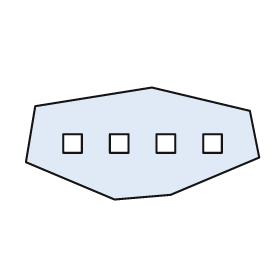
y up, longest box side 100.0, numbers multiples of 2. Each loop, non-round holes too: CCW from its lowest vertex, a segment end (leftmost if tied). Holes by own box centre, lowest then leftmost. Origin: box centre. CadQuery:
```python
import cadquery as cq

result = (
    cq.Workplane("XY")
    .moveTo(-12.0, -24.0)
    .lineTo(12.0, -22.0)
    .lineTo(50.0, -6.0)
    .lineTo(46.0, 14.0)
    .lineTo(4.0, 24.0)
    .lineTo(-46.0, 16.0)
    .lineTo(-50.0, -8.0)
    .close()
    .moveTo(-34.0, -4.0)
    .lineTo(-26.0, -4.0)
    .lineTo(-26.0, 4.0)
    .lineTo(-34.0, 4.0)
    .close()
    .moveTo(-14.0, -4.0)
    .lineTo(-6.0, -4.0)
    .lineTo(-6.0, 4.0)
    .lineTo(-14.0, 4.0)
    .close()
    .moveTo(6.0, -4.0)
    .lineTo(14.0, -4.0)
    .lineTo(14.0, 4.0)
    .lineTo(6.0, 4.0)
    .close()
    .moveTo(26.0, -4.0)
    .lineTo(34.0, -4.0)
    .lineTo(34.0, 4.0)
    .lineTo(26.0, 4.0)
    .close()
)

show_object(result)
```